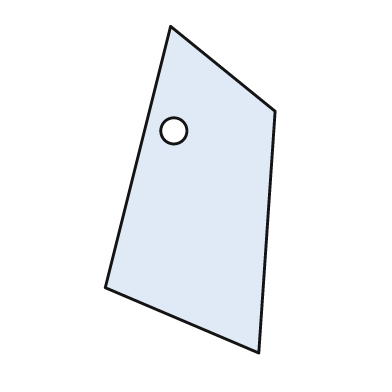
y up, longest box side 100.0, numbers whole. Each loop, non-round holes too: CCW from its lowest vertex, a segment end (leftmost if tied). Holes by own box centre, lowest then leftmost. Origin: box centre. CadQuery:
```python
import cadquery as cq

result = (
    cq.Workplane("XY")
    .moveTo(21.0, -50.0)
    .lineTo(26.0, 24.0)
    .lineTo(-6.0, 50.0)
    .lineTo(-26.0, -30.0)
    .close()
    .moveTo(-5.0, 18.0)
    .circle(4.0)
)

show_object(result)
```